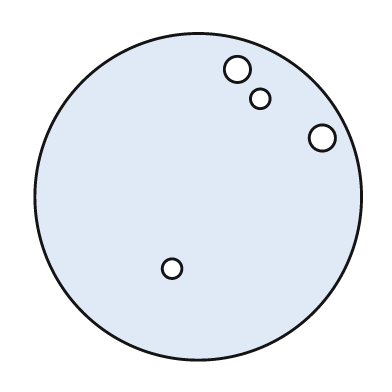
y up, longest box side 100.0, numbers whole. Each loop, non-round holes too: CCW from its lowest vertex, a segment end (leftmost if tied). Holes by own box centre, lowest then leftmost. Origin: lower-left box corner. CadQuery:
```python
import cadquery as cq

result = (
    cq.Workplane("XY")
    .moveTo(50.0, 50.0)
    .circle(50.0)
    .moveTo(42.0, 28.0)
    .circle(3.0)
    .moveTo(88.0, 68.0)
    .circle(4.0)
    .moveTo(69.0, 80.0)
    .circle(3.0)
    .moveTo(62.0, 89.0)
    .circle(4.0)
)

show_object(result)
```